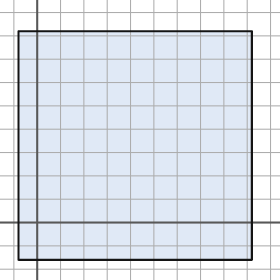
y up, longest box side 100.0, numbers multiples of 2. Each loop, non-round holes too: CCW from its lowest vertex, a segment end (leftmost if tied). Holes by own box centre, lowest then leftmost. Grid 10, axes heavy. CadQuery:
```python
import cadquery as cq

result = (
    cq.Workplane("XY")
    .moveTo(-8.0, -16.0)
    .lineTo(92.0, -16.0)
    .lineTo(92.0, 82.0)
    .lineTo(-8.0, 82.0)
    .close()
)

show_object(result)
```